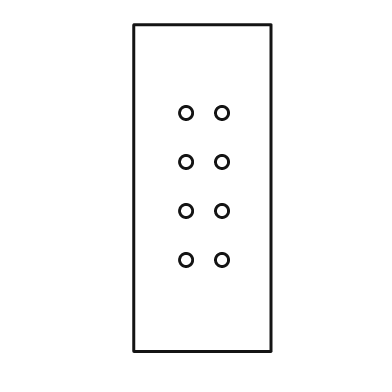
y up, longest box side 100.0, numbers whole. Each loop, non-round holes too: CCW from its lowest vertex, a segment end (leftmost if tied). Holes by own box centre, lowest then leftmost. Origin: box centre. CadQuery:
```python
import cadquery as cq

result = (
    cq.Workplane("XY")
    .moveTo(-21.0, -50.0)
    .lineTo(21.0, -50.0)
    .lineTo(21.0, 50.0)
    .lineTo(-21.0, 50.0)
    .close()
    .moveTo(-5.0, -22.0)
    .circle(2.0)
    .moveTo(6.0, -22.0)
    .circle(2.0)
    .moveTo(-5.0, -7.0)
    .circle(2.0)
    .moveTo(6.0, -7.0)
    .circle(2.0)
    .moveTo(-5.0, 8.0)
    .circle(2.0)
    .moveTo(6.0, 8.0)
    .circle(2.0)
    .moveTo(-5.0, 23.0)
    .circle(2.0)
    .moveTo(6.0, 23.0)
    .circle(2.0)
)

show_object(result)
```